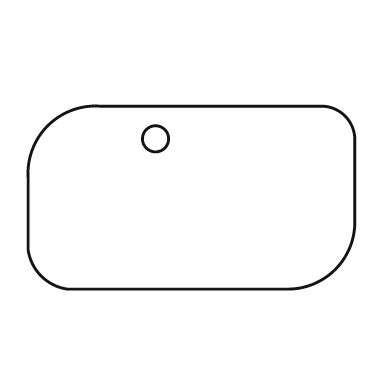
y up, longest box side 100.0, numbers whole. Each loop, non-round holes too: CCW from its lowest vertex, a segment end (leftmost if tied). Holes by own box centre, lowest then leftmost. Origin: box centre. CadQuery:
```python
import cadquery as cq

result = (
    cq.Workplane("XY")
    .moveTo(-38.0, -28.0)
    .lineTo(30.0, -28.0)
    .threePointArc((44.0, -22.0), (50.0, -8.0))
    .lineTo(50.0, 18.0)
    .threePointArc((47.0, 25.0), (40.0, 28.0))
    .lineTo(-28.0, 28.0)
    .threePointArc((-44.0, 22.0), (-50.0, 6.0))
    .lineTo(-50.0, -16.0)
    .threePointArc((-46.0, -24.0), (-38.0, -28.0))
    .close()
    .moveTo(-11.0, 18.0)
    .circle(4.0)
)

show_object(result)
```